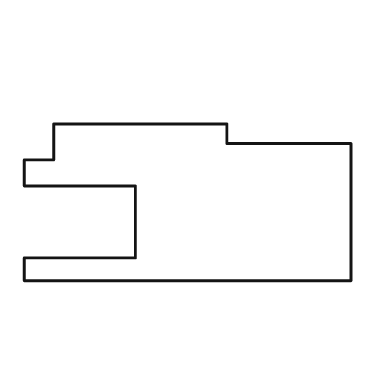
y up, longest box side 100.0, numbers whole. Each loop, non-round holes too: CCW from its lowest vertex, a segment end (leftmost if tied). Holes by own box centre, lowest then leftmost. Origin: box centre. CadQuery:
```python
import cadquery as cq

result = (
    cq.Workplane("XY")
    .moveTo(-50.0, -24.0)
    .lineTo(50.0, -24.0)
    .lineTo(50.0, 18.0)
    .lineTo(12.0, 18.0)
    .lineTo(12.0, 24.0)
    .lineTo(-41.0, 24.0)
    .lineTo(-41.0, 13.0)
    .lineTo(-50.0, 13.0)
    .lineTo(-50.0, 5.0)
    .lineTo(-16.0, 5.0)
    .lineTo(-16.0, -17.0)
    .lineTo(-50.0, -17.0)
    .close()
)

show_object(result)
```